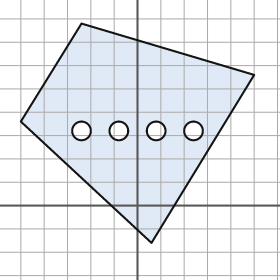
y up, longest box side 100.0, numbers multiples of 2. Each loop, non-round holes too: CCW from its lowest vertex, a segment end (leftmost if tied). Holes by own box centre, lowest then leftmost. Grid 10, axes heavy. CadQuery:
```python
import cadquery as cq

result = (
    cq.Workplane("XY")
    .moveTo(6.0, -16.0)
    .lineTo(50.0, 56.0)
    .lineTo(-24.0, 78.0)
    .lineTo(-50.0, 36.0)
    .close()
    .moveTo(-24.0, 32.0)
    .circle(4.0)
    .moveTo(-8.0, 32.0)
    .circle(4.0)
    .moveTo(8.0, 32.0)
    .circle(4.0)
    .moveTo(24.0, 32.0)
    .circle(4.0)
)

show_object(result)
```